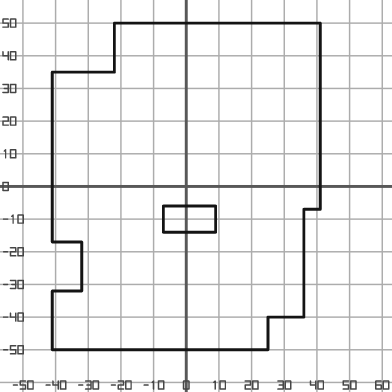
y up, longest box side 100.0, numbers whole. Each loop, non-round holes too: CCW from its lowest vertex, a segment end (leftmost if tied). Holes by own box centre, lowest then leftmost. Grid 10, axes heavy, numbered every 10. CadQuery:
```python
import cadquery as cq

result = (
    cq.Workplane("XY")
    .moveTo(-41.0, -50.0)
    .lineTo(25.0, -50.0)
    .lineTo(25.0, -40.0)
    .lineTo(36.0, -40.0)
    .lineTo(36.0, -7.0)
    .lineTo(41.0, -7.0)
    .lineTo(41.0, 50.0)
    .lineTo(-22.0, 50.0)
    .lineTo(-22.0, 35.0)
    .lineTo(-41.0, 35.0)
    .lineTo(-41.0, -17.0)
    .lineTo(-32.0, -17.0)
    .lineTo(-32.0, -32.0)
    .lineTo(-41.0, -32.0)
    .close()
    .moveTo(-7.0, -14.0)
    .lineTo(9.0, -14.0)
    .lineTo(9.0, -6.0)
    .lineTo(-7.0, -6.0)
    .close()
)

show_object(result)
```